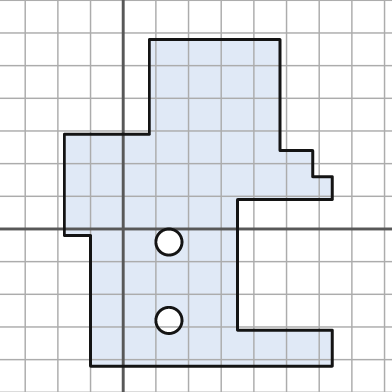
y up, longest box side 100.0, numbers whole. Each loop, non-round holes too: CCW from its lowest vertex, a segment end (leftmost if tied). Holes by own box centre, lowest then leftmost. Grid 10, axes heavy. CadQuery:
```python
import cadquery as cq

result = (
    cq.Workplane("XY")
    .moveTo(-10.0, -42.0)
    .lineTo(64.0, -42.0)
    .lineTo(64.0, -31.0)
    .lineTo(35.0, -31.0)
    .lineTo(35.0, 9.0)
    .lineTo(64.0, 9.0)
    .lineTo(64.0, 16.0)
    .lineTo(58.0, 16.0)
    .lineTo(58.0, 24.0)
    .lineTo(48.0, 24.0)
    .lineTo(48.0, 58.0)
    .lineTo(8.0, 58.0)
    .lineTo(8.0, 29.0)
    .lineTo(-18.0, 29.0)
    .lineTo(-18.0, -2.0)
    .lineTo(-10.0, -2.0)
    .close()
    .moveTo(14.0, -28.0)
    .circle(4.0)
    .moveTo(14.0, -4.0)
    .circle(4.0)
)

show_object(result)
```